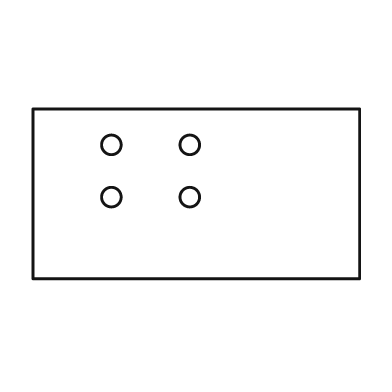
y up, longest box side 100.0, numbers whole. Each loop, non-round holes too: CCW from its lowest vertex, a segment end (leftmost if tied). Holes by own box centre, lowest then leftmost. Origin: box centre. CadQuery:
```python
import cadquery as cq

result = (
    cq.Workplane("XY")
    .moveTo(-50.0, -26.0)
    .lineTo(50.0, -26.0)
    .lineTo(50.0, 26.0)
    .lineTo(-50.0, 26.0)
    .close()
    .moveTo(-26.0, -1.0)
    .circle(3.0)
    .moveTo(-2.0, -1.0)
    .circle(3.0)
    .moveTo(-26.0, 15.0)
    .circle(3.0)
    .moveTo(-2.0, 15.0)
    .circle(3.0)
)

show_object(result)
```